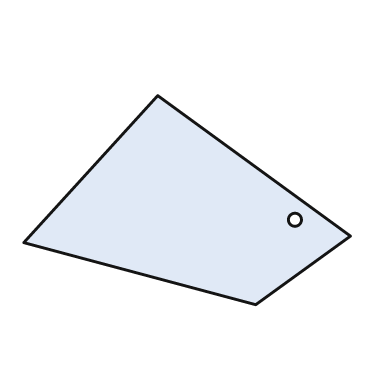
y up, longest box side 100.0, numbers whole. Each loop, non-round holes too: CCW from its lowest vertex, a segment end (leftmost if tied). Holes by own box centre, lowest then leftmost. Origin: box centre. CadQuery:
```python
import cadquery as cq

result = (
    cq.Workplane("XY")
    .moveTo(21.0, -32.0)
    .lineTo(50.0, -11.0)
    .lineTo(-9.0, 32.0)
    .lineTo(-50.0, -13.0)
    .close()
    .moveTo(33.0, -6.0)
    .circle(2.0)
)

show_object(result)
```